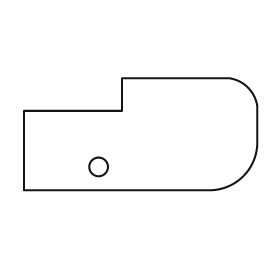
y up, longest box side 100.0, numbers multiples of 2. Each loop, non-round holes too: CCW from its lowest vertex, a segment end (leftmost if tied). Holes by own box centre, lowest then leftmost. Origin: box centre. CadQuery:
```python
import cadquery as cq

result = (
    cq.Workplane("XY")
    .moveTo(-50.0, -24.0)
    .lineTo(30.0, -24.0)
    .threePointArc((44.0, -18.0), (50.0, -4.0))
    .lineTo(50.0, 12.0)
    .threePointArc((46.0, 20.0), (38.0, 24.0))
    .lineTo(-8.0, 24.0)
    .lineTo(-8.0, 10.0)
    .lineTo(-50.0, 10.0)
    .close()
    .moveTo(-18.0, -14.0)
    .circle(4.0)
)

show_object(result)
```